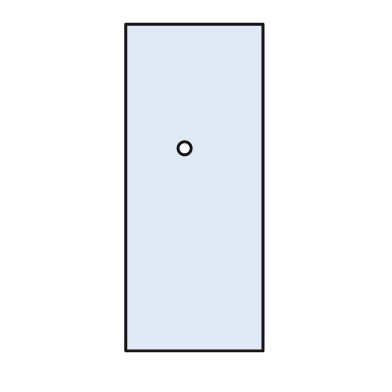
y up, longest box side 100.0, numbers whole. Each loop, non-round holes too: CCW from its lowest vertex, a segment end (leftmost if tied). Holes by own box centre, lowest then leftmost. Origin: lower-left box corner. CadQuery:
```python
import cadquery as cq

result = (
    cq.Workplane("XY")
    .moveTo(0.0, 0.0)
    .lineTo(42.0, 0.0)
    .lineTo(42.0, 100.0)
    .lineTo(0.0, 100.0)
    .close()
    .moveTo(18.0, 62.0)
    .circle(2.0)
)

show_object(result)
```